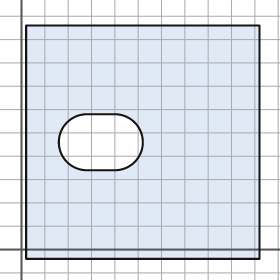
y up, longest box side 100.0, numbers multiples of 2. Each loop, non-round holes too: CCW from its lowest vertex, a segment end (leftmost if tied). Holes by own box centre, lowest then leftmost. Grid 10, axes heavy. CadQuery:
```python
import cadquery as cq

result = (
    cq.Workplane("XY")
    .moveTo(2.0, -4.0)
    .lineTo(102.0, -4.0)
    .lineTo(102.0, 96.0)
    .lineTo(2.0, 96.0)
    .close()
    .moveTo(28.0, 34.0)
    .lineTo(40.0, 34.0)
    .threePointArc((52.0, 46.0), (40.0, 58.0))
    .lineTo(28.0, 58.0)
    .threePointArc((16.0, 46.0), (28.0, 34.0))
    .close()
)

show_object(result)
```